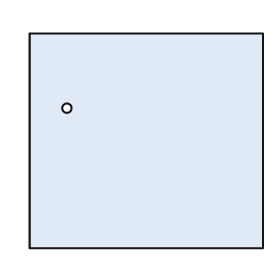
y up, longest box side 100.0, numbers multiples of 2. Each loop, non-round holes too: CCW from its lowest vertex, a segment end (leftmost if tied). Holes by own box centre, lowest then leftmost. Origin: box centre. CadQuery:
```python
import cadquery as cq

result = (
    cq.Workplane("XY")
    .moveTo(-50.0, -46.0)
    .lineTo(50.0, -46.0)
    .lineTo(50.0, 46.0)
    .lineTo(-50.0, 46.0)
    .close()
    .moveTo(-34.0, 14.0)
    .circle(2.0)
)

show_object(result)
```